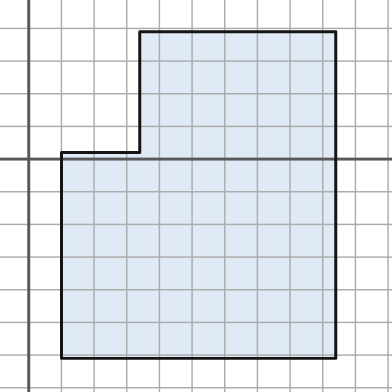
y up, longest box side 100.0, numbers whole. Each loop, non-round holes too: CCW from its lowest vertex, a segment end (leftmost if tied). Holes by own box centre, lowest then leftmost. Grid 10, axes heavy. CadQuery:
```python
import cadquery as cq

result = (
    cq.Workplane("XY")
    .moveTo(10.0, -61.0)
    .lineTo(94.0, -61.0)
    .lineTo(94.0, 39.0)
    .lineTo(34.0, 39.0)
    .lineTo(34.0, 2.0)
    .lineTo(10.0, 2.0)
    .close()
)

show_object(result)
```